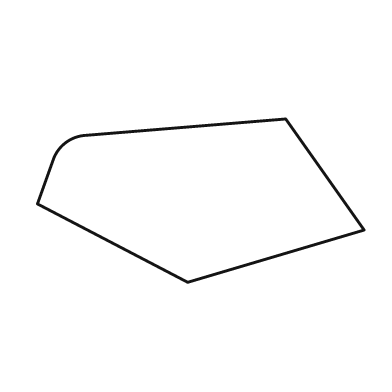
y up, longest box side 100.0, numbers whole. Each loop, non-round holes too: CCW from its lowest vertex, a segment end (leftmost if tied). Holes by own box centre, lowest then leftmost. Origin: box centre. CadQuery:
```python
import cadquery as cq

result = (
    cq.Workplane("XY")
    .moveTo(-4.0, -25.0)
    .lineTo(50.0, -9.0)
    .lineTo(26.0, 25.0)
    .lineTo(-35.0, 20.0)
    .threePointArc((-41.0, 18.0), (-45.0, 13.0))
    .lineTo(-50.0, -1.0)
    .close()
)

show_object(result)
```